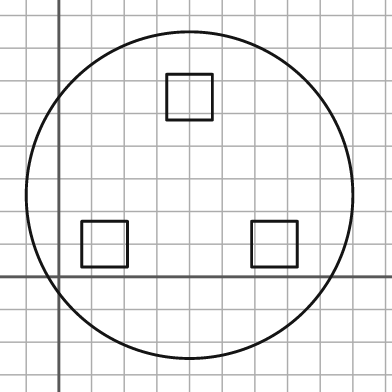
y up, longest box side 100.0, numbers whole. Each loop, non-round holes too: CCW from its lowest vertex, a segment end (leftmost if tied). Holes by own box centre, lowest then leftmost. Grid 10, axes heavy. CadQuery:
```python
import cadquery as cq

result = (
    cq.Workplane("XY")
    .moveTo(40.0, 25.0)
    .circle(50.0)
    .moveTo(7.0, 3.0)
    .lineTo(21.0, 3.0)
    .lineTo(21.0, 17.0)
    .lineTo(7.0, 17.0)
    .close()
    .moveTo(59.0, 3.0)
    .lineTo(73.0, 3.0)
    .lineTo(73.0, 17.0)
    .lineTo(59.0, 17.0)
    .close()
    .moveTo(33.0, 48.0)
    .lineTo(47.0, 48.0)
    .lineTo(47.0, 62.0)
    .lineTo(33.0, 62.0)
    .close()
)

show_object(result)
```